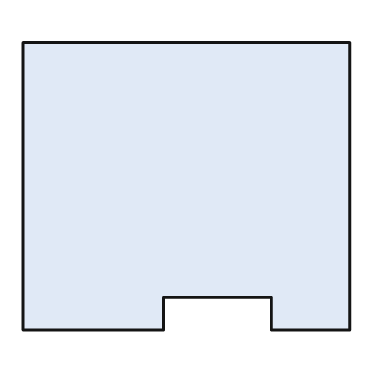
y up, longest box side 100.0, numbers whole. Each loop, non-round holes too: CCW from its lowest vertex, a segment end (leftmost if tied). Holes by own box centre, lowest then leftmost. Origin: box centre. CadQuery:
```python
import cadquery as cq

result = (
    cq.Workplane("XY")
    .moveTo(-50.0, -44.0)
    .lineTo(-7.0, -44.0)
    .lineTo(-7.0, -34.0)
    .lineTo(26.0, -34.0)
    .lineTo(26.0, -44.0)
    .lineTo(50.0, -44.0)
    .lineTo(50.0, 44.0)
    .lineTo(-50.0, 44.0)
    .close()
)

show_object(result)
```